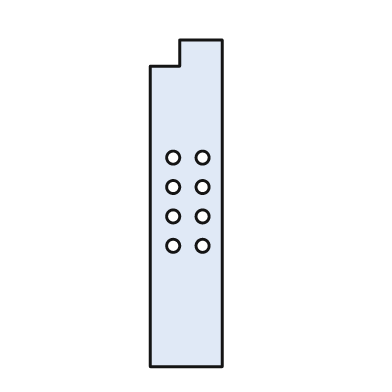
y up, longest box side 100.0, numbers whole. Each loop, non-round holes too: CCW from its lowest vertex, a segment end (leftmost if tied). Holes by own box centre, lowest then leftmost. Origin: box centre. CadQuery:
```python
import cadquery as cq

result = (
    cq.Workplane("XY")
    .moveTo(-11.0, -50.0)
    .lineTo(11.0, -50.0)
    .lineTo(11.0, 50.0)
    .lineTo(-2.0, 50.0)
    .lineTo(-2.0, 42.0)
    .lineTo(-11.0, 42.0)
    .close()
    .moveTo(-4.0, -13.0)
    .circle(2.0)
    .moveTo(5.0, -13.0)
    .circle(2.0)
    .moveTo(-4.0, -4.0)
    .circle(2.0)
    .moveTo(5.0, -4.0)
    .circle(2.0)
    .moveTo(-4.0, 5.0)
    .circle(2.0)
    .moveTo(5.0, 5.0)
    .circle(2.0)
    .moveTo(-4.0, 14.0)
    .circle(2.0)
    .moveTo(5.0, 14.0)
    .circle(2.0)
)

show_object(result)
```